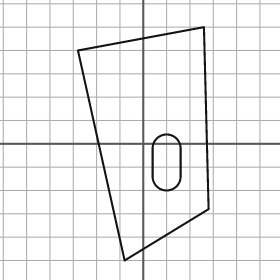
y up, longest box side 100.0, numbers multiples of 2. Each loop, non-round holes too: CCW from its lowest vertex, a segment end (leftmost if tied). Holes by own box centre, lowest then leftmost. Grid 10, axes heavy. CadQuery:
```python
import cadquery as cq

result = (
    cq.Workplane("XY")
    .moveTo(-8.0, -50.0)
    .lineTo(28.0, -28.0)
    .lineTo(26.0, 50.0)
    .lineTo(-28.0, 40.0)
    .close()
    .moveTo(4.0, -14.0)
    .threePointArc((10.0, -20.0), (16.0, -14.0))
    .lineTo(16.0, -2.0)
    .threePointArc((10.0, 4.0), (4.0, -2.0))
    .close()
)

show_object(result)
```